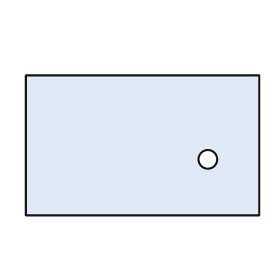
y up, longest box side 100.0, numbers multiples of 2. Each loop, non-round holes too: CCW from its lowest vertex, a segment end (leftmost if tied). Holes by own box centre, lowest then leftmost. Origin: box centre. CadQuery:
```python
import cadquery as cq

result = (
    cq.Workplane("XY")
    .moveTo(-50.0, -30.0)
    .lineTo(50.0, -30.0)
    .lineTo(50.0, 30.0)
    .lineTo(-50.0, 30.0)
    .close()
    .moveTo(28.0, -6.0)
    .circle(4.0)
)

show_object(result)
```